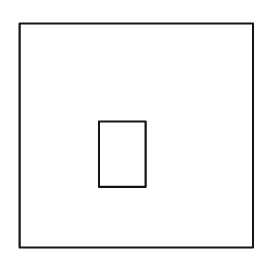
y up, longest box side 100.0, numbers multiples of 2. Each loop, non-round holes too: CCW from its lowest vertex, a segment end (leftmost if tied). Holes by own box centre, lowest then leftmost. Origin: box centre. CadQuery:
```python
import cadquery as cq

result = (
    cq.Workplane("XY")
    .moveTo(-50.0, -48.0)
    .lineTo(50.0, -48.0)
    .lineTo(50.0, 48.0)
    .lineTo(-50.0, 48.0)
    .close()
    .moveTo(-16.0, -22.0)
    .lineTo(4.0, -22.0)
    .lineTo(4.0, 6.0)
    .lineTo(-16.0, 6.0)
    .close()
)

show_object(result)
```